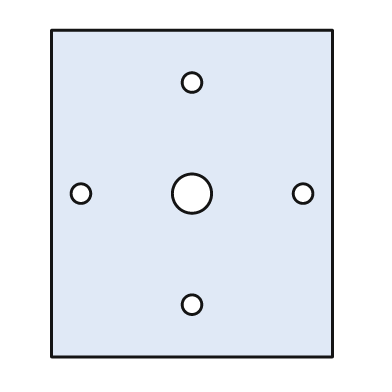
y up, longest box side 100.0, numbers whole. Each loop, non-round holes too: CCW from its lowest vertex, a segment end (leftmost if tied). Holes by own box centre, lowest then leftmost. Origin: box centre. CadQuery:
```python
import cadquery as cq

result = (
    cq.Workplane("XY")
    .moveTo(-43.0, -50.0)
    .lineTo(43.0, -50.0)
    .lineTo(43.0, 50.0)
    .lineTo(-43.0, 50.0)
    .close()
    .moveTo(0.0, -34.0)
    .circle(3.0)
    .moveTo(-34.0, 0.0)
    .circle(3.0)
    .moveTo(0.0, 0.0)
    .circle(6.0)
    .moveTo(34.0, 0.0)
    .circle(3.0)
    .moveTo(0.0, 34.0)
    .circle(3.0)
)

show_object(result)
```